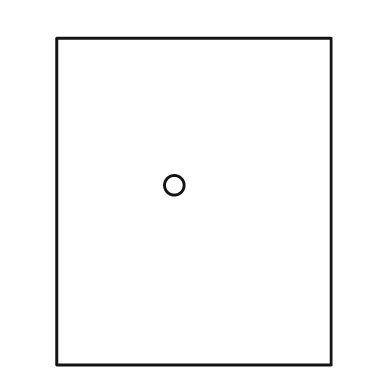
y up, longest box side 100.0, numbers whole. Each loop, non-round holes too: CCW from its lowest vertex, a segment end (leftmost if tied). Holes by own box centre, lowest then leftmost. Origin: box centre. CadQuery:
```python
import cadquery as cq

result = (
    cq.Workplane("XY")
    .moveTo(-42.0, -50.0)
    .lineTo(42.0, -50.0)
    .lineTo(42.0, 50.0)
    .lineTo(-42.0, 50.0)
    .close()
    .moveTo(-6.0, 5.0)
    .circle(3.0)
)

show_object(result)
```